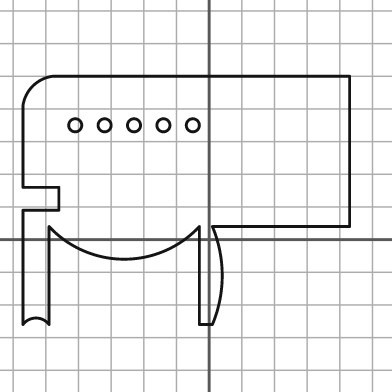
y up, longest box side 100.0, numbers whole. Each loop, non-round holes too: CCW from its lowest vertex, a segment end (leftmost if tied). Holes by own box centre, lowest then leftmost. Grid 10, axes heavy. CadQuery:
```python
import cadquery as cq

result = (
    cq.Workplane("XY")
    .moveTo(-57.0, -26.0)
    .threePointArc((-53.0, -24.0), (-49.0, -26.0))
    .lineTo(-49.0, 4.0)
    .threePointArc((-26.0, -6.0), (-3.0, 4.0))
    .lineTo(-3.0, -26.0)
    .lineTo(1.0, -26.0)
    .threePointArc((4.0, -11.0), (1.0, 4.0))
    .lineTo(43.0, 4.0)
    .lineTo(43.0, 50.0)
    .lineTo(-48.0, 50.0)
    .threePointArc((-54.0, 47.0), (-57.0, 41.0))
    .lineTo(-57.0, 16.0)
    .lineTo(-46.0, 16.0)
    .lineTo(-46.0, 9.0)
    .lineTo(-57.0, 9.0)
    .close()
    .moveTo(-41.0, 35.0)
    .circle(2.0)
    .moveTo(-32.0, 35.0)
    .circle(2.0)
    .moveTo(-23.0, 35.0)
    .circle(2.0)
    .moveTo(-14.0, 35.0)
    .circle(2.0)
    .moveTo(-5.0, 35.0)
    .circle(2.0)
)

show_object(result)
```